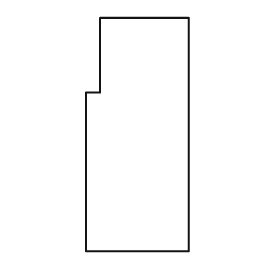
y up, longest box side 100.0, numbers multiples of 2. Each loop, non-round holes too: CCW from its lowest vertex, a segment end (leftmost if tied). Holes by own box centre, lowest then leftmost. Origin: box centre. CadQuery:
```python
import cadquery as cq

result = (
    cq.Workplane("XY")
    .moveTo(-22.0, -50.0)
    .lineTo(22.0, -50.0)
    .lineTo(22.0, 50.0)
    .lineTo(-16.0, 50.0)
    .lineTo(-16.0, 18.0)
    .lineTo(-22.0, 18.0)
    .close()
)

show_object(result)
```